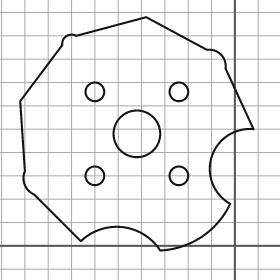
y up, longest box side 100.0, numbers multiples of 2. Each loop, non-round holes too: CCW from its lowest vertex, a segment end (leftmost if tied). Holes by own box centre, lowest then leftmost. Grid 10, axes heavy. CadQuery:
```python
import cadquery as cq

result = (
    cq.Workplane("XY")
    .moveTo(-32.0, -2.0)
    .threePointArc((-14.0, 4.0), (-2.0, 18.0))
    .threePointArc((-10.0, 38.0), (8.0, 50.0))
    .lineTo(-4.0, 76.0)
    .threePointArc((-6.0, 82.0), (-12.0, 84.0))
    .lineTo(-38.0, 98.0)
    .lineTo(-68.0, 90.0)
    .threePointArc((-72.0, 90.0), (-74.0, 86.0))
    .lineTo(-92.0, 62.0)
    .lineTo(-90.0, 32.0)
    .threePointArc((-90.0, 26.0), (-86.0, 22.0))
    .lineTo(-66.0, 2.0)
    .threePointArc((-48.0, 8.0), (-32.0, -2.0))
    .close()
    .moveTo(-60.0, 30.0)
    .circle(4.0)
    .moveTo(-24.0, 30.0)
    .circle(4.0)
    .moveTo(-42.0, 48.0)
    .circle(10.0)
    .moveTo(-60.0, 66.0)
    .circle(4.0)
    .moveTo(-24.0, 66.0)
    .circle(4.0)
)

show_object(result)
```